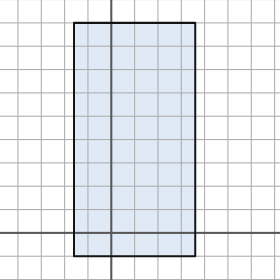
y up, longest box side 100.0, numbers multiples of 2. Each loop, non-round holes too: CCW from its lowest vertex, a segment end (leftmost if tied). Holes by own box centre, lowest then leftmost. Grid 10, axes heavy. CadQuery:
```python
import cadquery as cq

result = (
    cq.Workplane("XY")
    .moveTo(-16.0, -10.0)
    .lineTo(36.0, -10.0)
    .lineTo(36.0, 90.0)
    .lineTo(-16.0, 90.0)
    .close()
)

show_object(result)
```